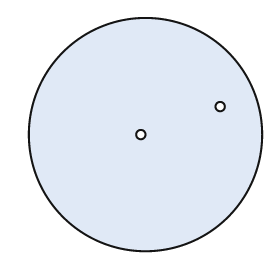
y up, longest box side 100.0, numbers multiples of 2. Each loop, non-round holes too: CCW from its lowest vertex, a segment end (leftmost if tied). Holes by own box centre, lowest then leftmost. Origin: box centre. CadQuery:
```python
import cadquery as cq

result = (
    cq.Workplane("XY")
    .moveTo(0.0, 0.0)
    .circle(50.0)
    .moveTo(-2.0, 0.0)
    .circle(2.0)
    .moveTo(32.0, 12.0)
    .circle(2.0)
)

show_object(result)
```